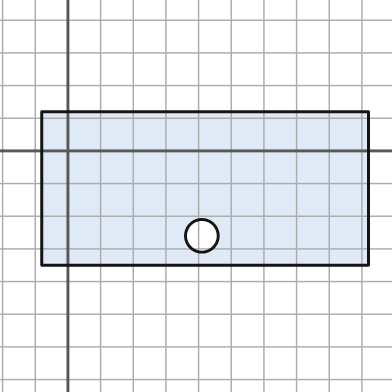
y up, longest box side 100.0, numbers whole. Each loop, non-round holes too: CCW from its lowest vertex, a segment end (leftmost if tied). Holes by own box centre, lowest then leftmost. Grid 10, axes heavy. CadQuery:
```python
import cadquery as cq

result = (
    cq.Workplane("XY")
    .moveTo(-8.0, -35.0)
    .lineTo(92.0, -35.0)
    .lineTo(92.0, 12.0)
    .lineTo(-8.0, 12.0)
    .close()
    .moveTo(41.0, -26.0)
    .circle(5.0)
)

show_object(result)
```